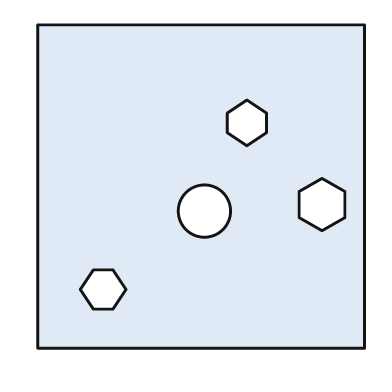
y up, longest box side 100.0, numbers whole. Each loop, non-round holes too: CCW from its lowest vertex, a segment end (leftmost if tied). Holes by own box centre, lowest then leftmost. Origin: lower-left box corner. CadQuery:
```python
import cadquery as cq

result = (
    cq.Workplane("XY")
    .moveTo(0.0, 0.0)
    .lineTo(100.0, 0.0)
    .lineTo(100.0, 99.0)
    .lineTo(0.0, 99.0)
    .close()
    .moveTo(17.0, 12.0)
    .lineTo(23.0, 12.0)
    .lineTo(27.0, 18.0)
    .lineTo(23.0, 24.0)
    .lineTo(17.0, 24.0)
    .lineTo(13.0, 18.0)
    .close()
    .moveTo(51.0, 42.0)
    .circle(8.0)
    .moveTo(87.0, 36.0)
    .lineTo(94.0, 40.0)
    .lineTo(94.0, 48.0)
    .lineTo(87.0, 52.0)
    .lineTo(80.0, 48.0)
    .lineTo(80.0, 40.0)
    .close()
    .moveTo(64.0, 62.0)
    .lineTo(70.0, 66.0)
    .lineTo(70.0, 72.0)
    .lineTo(64.0, 76.0)
    .lineTo(58.0, 72.0)
    .lineTo(58.0, 66.0)
    .close()
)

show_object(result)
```